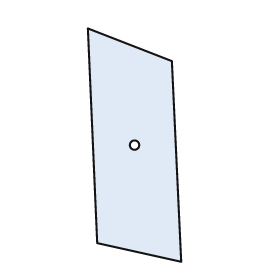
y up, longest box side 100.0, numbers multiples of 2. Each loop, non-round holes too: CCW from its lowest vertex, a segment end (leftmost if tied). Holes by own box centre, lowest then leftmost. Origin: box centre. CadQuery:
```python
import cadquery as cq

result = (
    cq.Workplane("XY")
    .moveTo(20.0, -50.0)
    .lineTo(16.0, 36.0)
    .lineTo(-20.0, 50.0)
    .lineTo(-16.0, -42.0)
    .close()
    .moveTo(0.0, 0.0)
    .circle(2.0)
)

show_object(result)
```